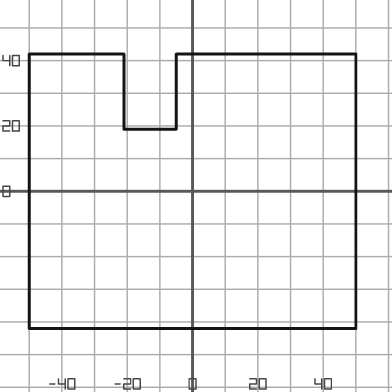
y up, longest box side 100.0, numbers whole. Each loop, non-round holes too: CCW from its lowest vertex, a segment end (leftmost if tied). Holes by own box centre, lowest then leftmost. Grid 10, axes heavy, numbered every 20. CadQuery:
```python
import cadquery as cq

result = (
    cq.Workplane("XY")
    .moveTo(-50.0, -42.0)
    .lineTo(50.0, -42.0)
    .lineTo(50.0, 42.0)
    .lineTo(-5.0, 42.0)
    .lineTo(-5.0, 19.0)
    .lineTo(-21.0, 19.0)
    .lineTo(-21.0, 42.0)
    .lineTo(-50.0, 42.0)
    .close()
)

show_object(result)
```